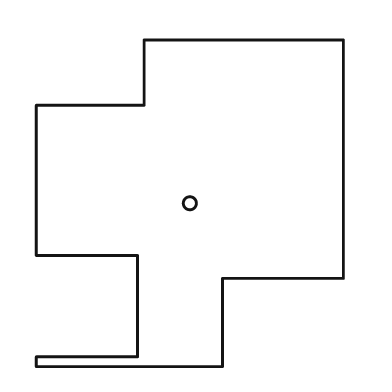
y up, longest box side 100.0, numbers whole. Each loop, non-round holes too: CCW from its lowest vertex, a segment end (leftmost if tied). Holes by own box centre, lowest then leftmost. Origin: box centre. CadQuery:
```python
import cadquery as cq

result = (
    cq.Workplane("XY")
    .moveTo(-47.0, -50.0)
    .lineTo(10.0, -50.0)
    .lineTo(10.0, -23.0)
    .lineTo(47.0, -23.0)
    .lineTo(47.0, 50.0)
    .lineTo(-14.0, 50.0)
    .lineTo(-14.0, 30.0)
    .lineTo(-47.0, 30.0)
    .lineTo(-47.0, -16.0)
    .lineTo(-16.0, -16.0)
    .lineTo(-16.0, -47.0)
    .lineTo(-47.0, -47.0)
    .close()
    .moveTo(0.0, 0.0)
    .circle(2.0)
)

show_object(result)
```